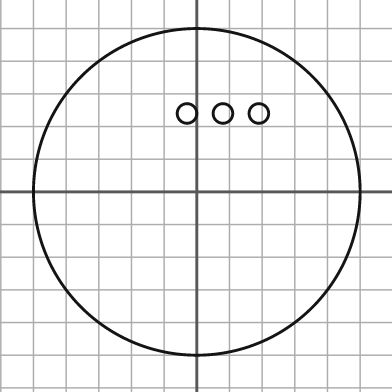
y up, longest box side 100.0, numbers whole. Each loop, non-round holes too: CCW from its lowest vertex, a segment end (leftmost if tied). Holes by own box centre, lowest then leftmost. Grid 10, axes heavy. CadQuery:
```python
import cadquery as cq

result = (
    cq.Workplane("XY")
    .moveTo(0.0, 0.0)
    .circle(50.0)
    .moveTo(-3.0, 24.0)
    .circle(3.0)
    .moveTo(8.0, 24.0)
    .circle(3.0)
    .moveTo(19.0, 24.0)
    .circle(3.0)
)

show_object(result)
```